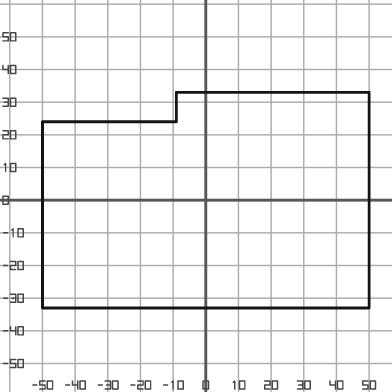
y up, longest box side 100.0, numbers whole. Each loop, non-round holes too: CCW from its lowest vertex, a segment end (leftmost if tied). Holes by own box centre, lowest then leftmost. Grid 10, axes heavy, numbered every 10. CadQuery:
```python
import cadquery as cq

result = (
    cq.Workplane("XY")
    .moveTo(-50.0, -33.0)
    .lineTo(50.0, -33.0)
    .lineTo(50.0, 33.0)
    .lineTo(-9.0, 33.0)
    .lineTo(-9.0, 24.0)
    .lineTo(-50.0, 24.0)
    .close()
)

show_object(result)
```